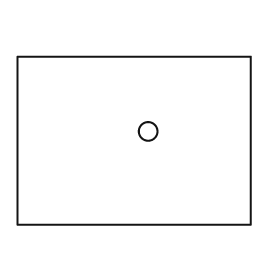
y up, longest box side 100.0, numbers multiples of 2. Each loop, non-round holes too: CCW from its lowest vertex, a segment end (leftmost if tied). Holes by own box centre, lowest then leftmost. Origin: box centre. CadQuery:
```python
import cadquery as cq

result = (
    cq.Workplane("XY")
    .moveTo(-50.0, -36.0)
    .lineTo(50.0, -36.0)
    .lineTo(50.0, 36.0)
    .lineTo(-50.0, 36.0)
    .close()
    .moveTo(6.0, 4.0)
    .circle(4.0)
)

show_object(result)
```